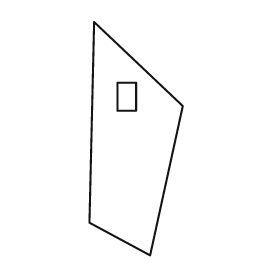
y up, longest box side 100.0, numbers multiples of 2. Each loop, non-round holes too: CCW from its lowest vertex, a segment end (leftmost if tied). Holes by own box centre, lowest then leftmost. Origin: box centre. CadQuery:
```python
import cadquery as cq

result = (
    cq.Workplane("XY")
    .moveTo(6.0, -50.0)
    .lineTo(20.0, 14.0)
    .lineTo(-18.0, 50.0)
    .lineTo(-20.0, -36.0)
    .close()
    .moveTo(-8.0, 12.0)
    .lineTo(0.0, 12.0)
    .lineTo(0.0, 24.0)
    .lineTo(-8.0, 24.0)
    .close()
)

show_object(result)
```